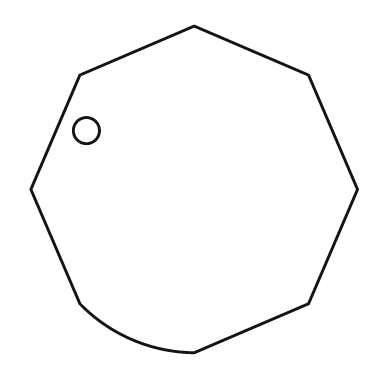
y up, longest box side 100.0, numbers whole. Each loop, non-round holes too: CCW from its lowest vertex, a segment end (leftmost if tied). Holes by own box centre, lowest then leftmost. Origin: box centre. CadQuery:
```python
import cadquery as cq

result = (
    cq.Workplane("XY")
    .moveTo(0.0, -50.0)
    .lineTo(35.0, -35.0)
    .lineTo(50.0, 0.0)
    .lineTo(35.0, 35.0)
    .lineTo(0.0, 50.0)
    .lineTo(-35.0, 35.0)
    .lineTo(-50.0, 0.0)
    .lineTo(-35.0, -35.0)
    .threePointArc((-19.0, -46.0), (0.0, -50.0))
    .close()
    .moveTo(-33.0, 18.0)
    .circle(4.0)
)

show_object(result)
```